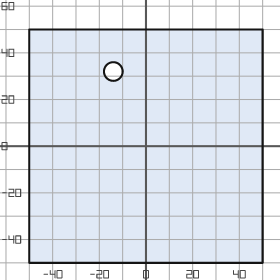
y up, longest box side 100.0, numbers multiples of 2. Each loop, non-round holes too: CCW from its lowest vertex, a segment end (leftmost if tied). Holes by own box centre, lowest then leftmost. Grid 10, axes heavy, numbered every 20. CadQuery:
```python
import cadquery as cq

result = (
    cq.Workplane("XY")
    .moveTo(-50.0, -50.0)
    .lineTo(50.0, -50.0)
    .lineTo(50.0, 50.0)
    .lineTo(-50.0, 50.0)
    .close()
    .moveTo(-14.0, 32.0)
    .circle(4.0)
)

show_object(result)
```